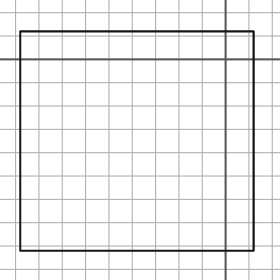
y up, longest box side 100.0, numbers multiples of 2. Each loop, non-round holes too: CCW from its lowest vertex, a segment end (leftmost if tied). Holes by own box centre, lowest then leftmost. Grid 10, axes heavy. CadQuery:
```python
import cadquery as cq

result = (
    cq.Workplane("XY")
    .moveTo(-88.0, -82.0)
    .lineTo(12.0, -82.0)
    .lineTo(12.0, 12.0)
    .lineTo(-88.0, 12.0)
    .close()
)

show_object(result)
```